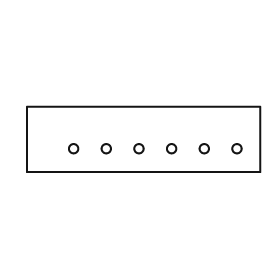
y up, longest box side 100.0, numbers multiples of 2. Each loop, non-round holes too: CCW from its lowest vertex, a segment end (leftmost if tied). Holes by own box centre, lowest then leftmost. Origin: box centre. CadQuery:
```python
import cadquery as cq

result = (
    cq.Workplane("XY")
    .moveTo(-50.0, -14.0)
    .lineTo(50.0, -14.0)
    .lineTo(50.0, 14.0)
    .lineTo(-50.0, 14.0)
    .close()
    .moveTo(-30.0, -4.0)
    .circle(2.0)
    .moveTo(-16.0, -4.0)
    .circle(2.0)
    .moveTo(-2.0, -4.0)
    .circle(2.0)
    .moveTo(12.0, -4.0)
    .circle(2.0)
    .moveTo(26.0, -4.0)
    .circle(2.0)
    .moveTo(40.0, -4.0)
    .circle(2.0)
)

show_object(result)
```